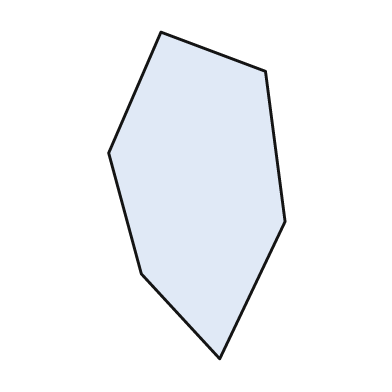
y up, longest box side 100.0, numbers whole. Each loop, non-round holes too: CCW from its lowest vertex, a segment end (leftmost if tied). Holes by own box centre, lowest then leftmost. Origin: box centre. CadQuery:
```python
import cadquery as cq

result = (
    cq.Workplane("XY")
    .moveTo(7.0, -50.0)
    .lineTo(27.0, -8.0)
    .lineTo(21.0, 38.0)
    .lineTo(-11.0, 50.0)
    .lineTo(-27.0, 13.0)
    .lineTo(-17.0, -24.0)
    .close()
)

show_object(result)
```